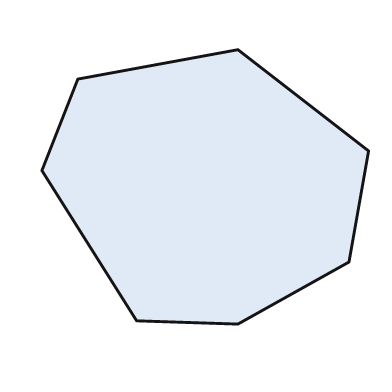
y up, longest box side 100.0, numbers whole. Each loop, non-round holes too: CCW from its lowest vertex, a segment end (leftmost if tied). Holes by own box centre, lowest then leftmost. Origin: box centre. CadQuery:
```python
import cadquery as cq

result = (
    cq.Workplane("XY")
    .moveTo(10.0, -42.0)
    .lineTo(44.0, -23.0)
    .lineTo(50.0, 11.0)
    .lineTo(10.0, 42.0)
    .lineTo(-39.0, 33.0)
    .lineTo(-50.0, 5.0)
    .lineTo(-21.0, -41.0)
    .close()
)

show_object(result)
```